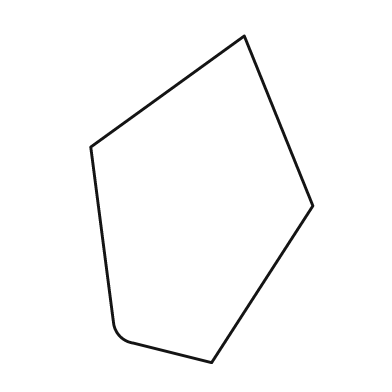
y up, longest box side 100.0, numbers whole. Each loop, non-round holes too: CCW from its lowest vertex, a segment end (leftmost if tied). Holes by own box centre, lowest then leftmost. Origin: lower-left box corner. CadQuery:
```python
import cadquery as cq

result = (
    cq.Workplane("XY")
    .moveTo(37.0, 0.0)
    .lineTo(68.0, 48.0)
    .lineTo(47.0, 100.0)
    .lineTo(0.0, 66.0)
    .lineTo(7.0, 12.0)
    .threePointArc((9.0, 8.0), (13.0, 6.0))
    .close()
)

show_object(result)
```